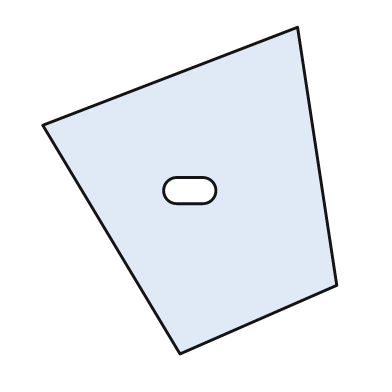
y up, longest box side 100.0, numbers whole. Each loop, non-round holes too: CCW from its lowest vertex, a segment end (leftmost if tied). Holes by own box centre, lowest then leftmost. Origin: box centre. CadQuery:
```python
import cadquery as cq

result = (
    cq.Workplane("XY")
    .moveTo(-3.0, -50.0)
    .lineTo(45.0, -29.0)
    .lineTo(33.0, 50.0)
    .lineTo(-45.0, 20.0)
    .close()
    .moveTo(-4.0, -4.0)
    .lineTo(4.0, -4.0)
    .threePointArc((8.0, 0.0), (4.0, 4.0))
    .lineTo(-4.0, 4.0)
    .threePointArc((-8.0, 0.0), (-4.0, -4.0))
    .close()
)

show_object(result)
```